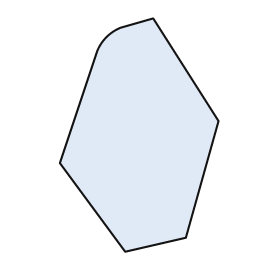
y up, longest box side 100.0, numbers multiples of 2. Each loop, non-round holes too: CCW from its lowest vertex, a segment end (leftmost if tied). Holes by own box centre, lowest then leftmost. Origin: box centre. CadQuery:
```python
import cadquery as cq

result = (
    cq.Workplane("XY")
    .moveTo(-6.0, -50.0)
    .lineTo(20.0, -44.0)
    .lineTo(34.0, 6.0)
    .lineTo(6.0, 50.0)
    .lineTo(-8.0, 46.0)
    .threePointArc((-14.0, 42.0), (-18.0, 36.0))
    .lineTo(-34.0, -12.0)
    .close()
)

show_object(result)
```